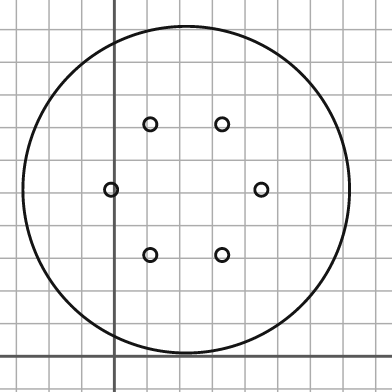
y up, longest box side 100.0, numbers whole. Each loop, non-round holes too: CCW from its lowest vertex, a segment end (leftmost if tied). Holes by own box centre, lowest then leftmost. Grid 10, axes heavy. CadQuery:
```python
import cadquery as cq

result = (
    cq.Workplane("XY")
    .moveTo(22.0, 51.0)
    .circle(50.0)
    .moveTo(11.0, 31.0)
    .circle(2.0)
    .moveTo(33.0, 31.0)
    .circle(2.0)
    .moveTo(-1.0, 51.0)
    .circle(2.0)
    .moveTo(45.0, 51.0)
    .circle(2.0)
    .moveTo(11.0, 71.0)
    .circle(2.0)
    .moveTo(33.0, 71.0)
    .circle(2.0)
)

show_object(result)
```